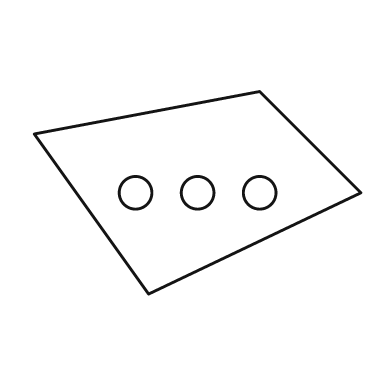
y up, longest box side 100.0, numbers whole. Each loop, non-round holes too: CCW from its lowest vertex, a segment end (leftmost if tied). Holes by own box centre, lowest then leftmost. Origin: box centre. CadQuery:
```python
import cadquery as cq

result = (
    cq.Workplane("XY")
    .moveTo(-15.0, -31.0)
    .lineTo(50.0, 0.0)
    .lineTo(19.0, 31.0)
    .lineTo(-50.0, 18.0)
    .close()
    .moveTo(-19.0, 0.0)
    .circle(5.0)
    .moveTo(0.0, 0.0)
    .circle(5.0)
    .moveTo(19.0, 0.0)
    .circle(5.0)
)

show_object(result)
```